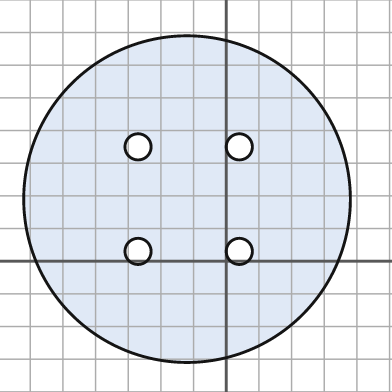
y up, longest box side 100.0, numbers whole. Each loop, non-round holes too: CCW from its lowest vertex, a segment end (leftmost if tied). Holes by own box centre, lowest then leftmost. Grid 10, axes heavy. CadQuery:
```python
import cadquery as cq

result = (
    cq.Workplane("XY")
    .moveTo(-12.0, 19.0)
    .circle(50.0)
    .moveTo(-27.0, 3.0)
    .circle(4.0)
    .moveTo(4.0, 3.0)
    .circle(4.0)
    .moveTo(-27.0, 35.0)
    .circle(4.0)
    .moveTo(4.0, 35.0)
    .circle(4.0)
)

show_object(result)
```